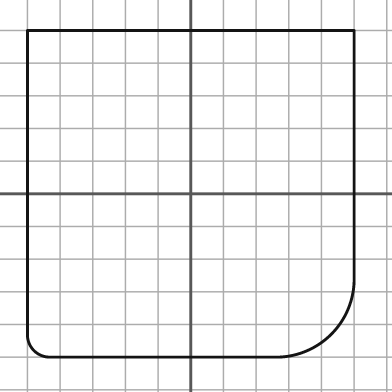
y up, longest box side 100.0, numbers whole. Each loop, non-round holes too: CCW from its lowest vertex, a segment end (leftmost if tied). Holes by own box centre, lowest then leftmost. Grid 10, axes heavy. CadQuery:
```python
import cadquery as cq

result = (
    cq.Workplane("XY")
    .moveTo(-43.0, -50.0)
    .lineTo(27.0, -50.0)
    .threePointArc((43.0, -43.0), (50.0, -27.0))
    .lineTo(50.0, 50.0)
    .lineTo(-50.0, 50.0)
    .lineTo(-50.0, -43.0)
    .threePointArc((-48.0, -48.0), (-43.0, -50.0))
    .close()
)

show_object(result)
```